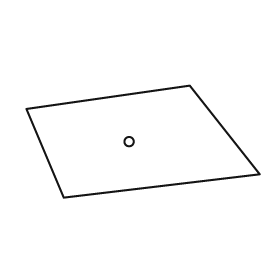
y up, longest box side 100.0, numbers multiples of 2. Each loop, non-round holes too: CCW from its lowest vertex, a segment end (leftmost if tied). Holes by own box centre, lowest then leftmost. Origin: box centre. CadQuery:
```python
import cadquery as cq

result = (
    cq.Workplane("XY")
    .moveTo(-34.0, -24.0)
    .lineTo(50.0, -14.0)
    .lineTo(20.0, 24.0)
    .lineTo(-50.0, 14.0)
    .close()
    .moveTo(-6.0, 0.0)
    .circle(2.0)
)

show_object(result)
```